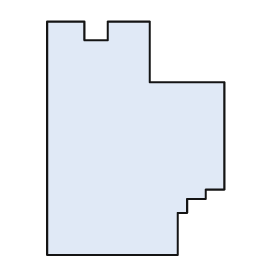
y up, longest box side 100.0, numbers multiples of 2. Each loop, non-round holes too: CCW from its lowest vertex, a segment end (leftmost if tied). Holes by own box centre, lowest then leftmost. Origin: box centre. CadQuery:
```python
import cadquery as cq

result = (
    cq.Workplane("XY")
    .moveTo(-38.0, -50.0)
    .lineTo(18.0, -50.0)
    .lineTo(18.0, -32.0)
    .lineTo(22.0, -32.0)
    .lineTo(22.0, -26.0)
    .lineTo(30.0, -26.0)
    .lineTo(30.0, -22.0)
    .lineTo(38.0, -22.0)
    .lineTo(38.0, 24.0)
    .lineTo(6.0, 24.0)
    .lineTo(6.0, 50.0)
    .lineTo(-12.0, 50.0)
    .lineTo(-12.0, 42.0)
    .lineTo(-22.0, 42.0)
    .lineTo(-22.0, 50.0)
    .lineTo(-38.0, 50.0)
    .close()
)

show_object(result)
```